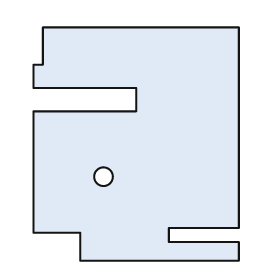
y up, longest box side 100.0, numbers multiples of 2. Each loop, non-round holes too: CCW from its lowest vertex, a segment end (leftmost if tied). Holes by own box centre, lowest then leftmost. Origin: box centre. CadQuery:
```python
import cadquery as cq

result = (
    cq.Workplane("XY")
    .moveTo(-24.0, -50.0)
    .lineTo(44.0, -50.0)
    .lineTo(44.0, -42.0)
    .lineTo(14.0, -42.0)
    .lineTo(14.0, -36.0)
    .lineTo(44.0, -36.0)
    .lineTo(44.0, 50.0)
    .lineTo(-40.0, 50.0)
    .lineTo(-40.0, 34.0)
    .lineTo(-44.0, 34.0)
    .lineTo(-44.0, 24.0)
    .lineTo(0.0, 24.0)
    .lineTo(0.0, 14.0)
    .lineTo(-44.0, 14.0)
    .lineTo(-44.0, -38.0)
    .lineTo(-24.0, -38.0)
    .close()
    .moveTo(-14.0, -14.0)
    .circle(4.0)
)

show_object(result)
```